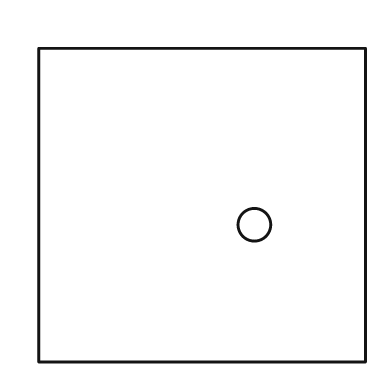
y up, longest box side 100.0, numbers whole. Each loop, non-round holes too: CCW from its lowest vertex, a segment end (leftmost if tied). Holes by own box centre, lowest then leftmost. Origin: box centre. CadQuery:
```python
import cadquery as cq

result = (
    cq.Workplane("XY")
    .moveTo(-50.0, -48.0)
    .lineTo(50.0, -48.0)
    .lineTo(50.0, 48.0)
    .lineTo(-50.0, 48.0)
    .close()
    .moveTo(16.0, -6.0)
    .circle(5.0)
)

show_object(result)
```